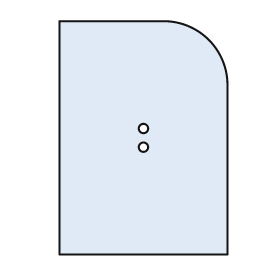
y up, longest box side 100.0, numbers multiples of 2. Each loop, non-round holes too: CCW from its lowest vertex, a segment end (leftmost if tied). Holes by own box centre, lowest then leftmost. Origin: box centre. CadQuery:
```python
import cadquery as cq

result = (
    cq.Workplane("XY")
    .moveTo(-36.0, -50.0)
    .lineTo(36.0, -50.0)
    .lineTo(36.0, 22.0)
    .threePointArc((28.0, 42.0), (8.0, 50.0))
    .lineTo(-36.0, 50.0)
    .close()
    .moveTo(0.0, -4.0)
    .circle(2.0)
    .moveTo(0.0, 4.0)
    .circle(2.0)
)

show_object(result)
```